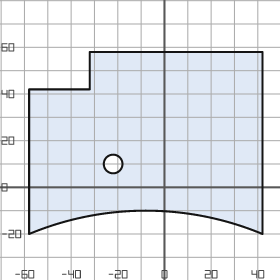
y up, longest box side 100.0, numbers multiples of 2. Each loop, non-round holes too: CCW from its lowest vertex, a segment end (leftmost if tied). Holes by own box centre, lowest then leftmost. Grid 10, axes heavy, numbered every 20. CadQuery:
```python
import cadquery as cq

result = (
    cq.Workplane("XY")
    .moveTo(-58.0, -20.0)
    .threePointArc((-8.0, -10.0), (42.0, -20.0))
    .lineTo(42.0, 58.0)
    .lineTo(-32.0, 58.0)
    .lineTo(-32.0, 42.0)
    .lineTo(-58.0, 42.0)
    .close()
    .moveTo(-22.0, 10.0)
    .circle(4.0)
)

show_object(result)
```